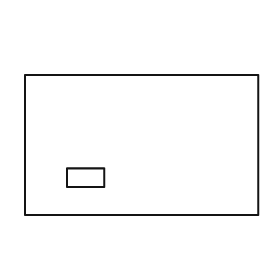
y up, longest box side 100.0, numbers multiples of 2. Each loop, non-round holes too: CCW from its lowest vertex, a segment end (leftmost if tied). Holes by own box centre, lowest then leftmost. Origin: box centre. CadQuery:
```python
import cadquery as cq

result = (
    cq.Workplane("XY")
    .moveTo(-50.0, -30.0)
    .lineTo(50.0, -30.0)
    .lineTo(50.0, 30.0)
    .lineTo(-50.0, 30.0)
    .close()
    .moveTo(-32.0, -18.0)
    .lineTo(-16.0, -18.0)
    .lineTo(-16.0, -10.0)
    .lineTo(-32.0, -10.0)
    .close()
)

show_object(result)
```